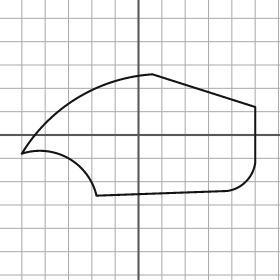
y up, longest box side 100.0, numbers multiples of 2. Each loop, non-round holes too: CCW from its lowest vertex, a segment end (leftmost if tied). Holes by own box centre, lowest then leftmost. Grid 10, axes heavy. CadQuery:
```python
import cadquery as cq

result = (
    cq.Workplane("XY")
    .moveTo(-18.0, -26.0)
    .lineTo(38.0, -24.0)
    .threePointArc((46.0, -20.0), (50.0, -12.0))
    .lineTo(50.0, 12.0)
    .lineTo(6.0, 26.0)
    .threePointArc((-26.0, 16.0), (-50.0, -8.0))
    .threePointArc((-30.0, -10.0), (-18.0, -26.0))
    .close()
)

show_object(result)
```